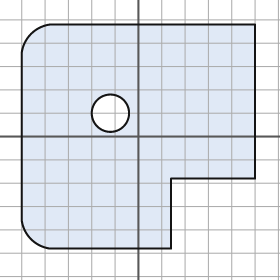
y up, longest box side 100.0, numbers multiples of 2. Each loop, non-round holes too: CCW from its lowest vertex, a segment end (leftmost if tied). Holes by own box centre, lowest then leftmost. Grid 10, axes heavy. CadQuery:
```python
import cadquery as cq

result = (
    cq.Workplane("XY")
    .moveTo(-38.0, -48.0)
    .lineTo(14.0, -48.0)
    .lineTo(14.0, -18.0)
    .lineTo(50.0, -18.0)
    .lineTo(50.0, 48.0)
    .lineTo(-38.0, 48.0)
    .threePointArc((-46.0, 44.0), (-50.0, 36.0))
    .lineTo(-50.0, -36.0)
    .threePointArc((-46.0, -44.0), (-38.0, -48.0))
    .close()
    .moveTo(-12.0, 10.0)
    .circle(8.0)
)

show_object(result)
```